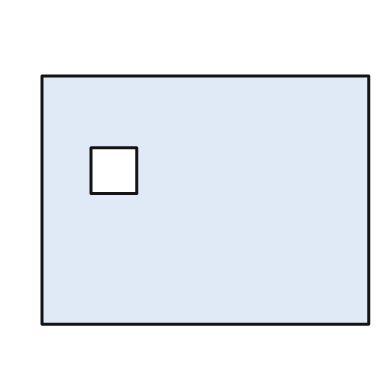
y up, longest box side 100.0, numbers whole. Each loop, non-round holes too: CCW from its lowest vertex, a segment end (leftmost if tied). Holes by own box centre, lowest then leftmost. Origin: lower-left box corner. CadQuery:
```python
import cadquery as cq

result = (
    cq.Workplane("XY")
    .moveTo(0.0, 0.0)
    .lineTo(100.0, 0.0)
    .lineTo(100.0, 76.0)
    .lineTo(0.0, 76.0)
    .close()
    .moveTo(15.0, 40.0)
    .lineTo(29.0, 40.0)
    .lineTo(29.0, 54.0)
    .lineTo(15.0, 54.0)
    .close()
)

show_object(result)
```